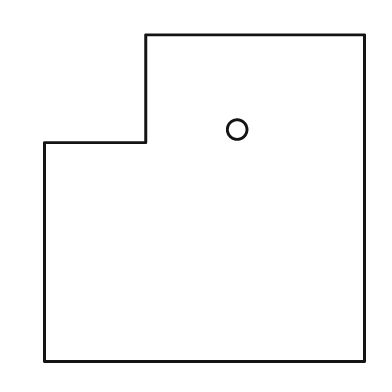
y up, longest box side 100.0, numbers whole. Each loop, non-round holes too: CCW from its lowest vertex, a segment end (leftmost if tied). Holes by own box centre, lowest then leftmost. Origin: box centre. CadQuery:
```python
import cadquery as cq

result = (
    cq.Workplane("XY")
    .moveTo(-49.0, -50.0)
    .lineTo(49.0, -50.0)
    .lineTo(49.0, 50.0)
    .lineTo(-18.0, 50.0)
    .lineTo(-18.0, 17.0)
    .lineTo(-49.0, 17.0)
    .close()
    .moveTo(10.0, 21.0)
    .circle(3.0)
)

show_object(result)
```